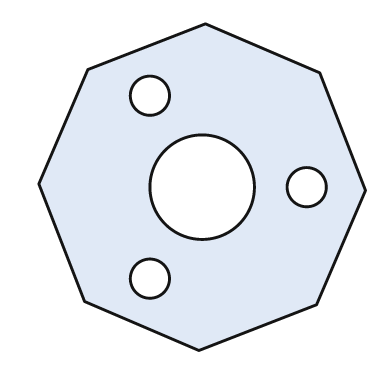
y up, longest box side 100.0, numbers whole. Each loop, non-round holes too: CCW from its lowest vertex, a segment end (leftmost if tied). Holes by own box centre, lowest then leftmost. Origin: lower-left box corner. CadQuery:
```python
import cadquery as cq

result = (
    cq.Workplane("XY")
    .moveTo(49.0, 0.0)
    .lineTo(85.0, 14.0)
    .lineTo(100.0, 49.0)
    .lineTo(86.0, 85.0)
    .lineTo(51.0, 100.0)
    .lineTo(15.0, 86.0)
    .lineTo(0.0, 51.0)
    .lineTo(14.0, 15.0)
    .close()
    .moveTo(34.0, 22.0)
    .circle(6.0)
    .moveTo(50.0, 50.0)
    .circle(16.0)
    .moveTo(82.0, 50.0)
    .circle(6.0)
    .moveTo(34.0, 78.0)
    .circle(6.0)
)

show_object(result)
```